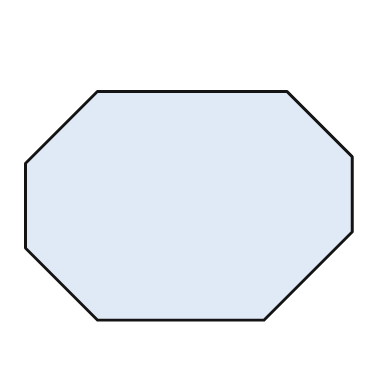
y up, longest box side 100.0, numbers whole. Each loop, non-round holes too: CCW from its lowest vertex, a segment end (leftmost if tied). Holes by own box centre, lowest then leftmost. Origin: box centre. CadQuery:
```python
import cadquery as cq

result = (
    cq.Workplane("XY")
    .moveTo(-28.0, -35.0)
    .lineTo(23.0, -35.0)
    .lineTo(50.0, -8.0)
    .lineTo(50.0, 15.0)
    .lineTo(30.0, 35.0)
    .lineTo(-28.0, 35.0)
    .lineTo(-50.0, 13.0)
    .lineTo(-50.0, -13.0)
    .close()
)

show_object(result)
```